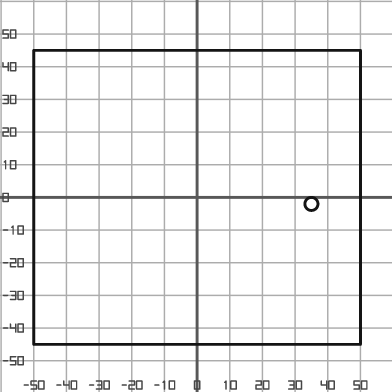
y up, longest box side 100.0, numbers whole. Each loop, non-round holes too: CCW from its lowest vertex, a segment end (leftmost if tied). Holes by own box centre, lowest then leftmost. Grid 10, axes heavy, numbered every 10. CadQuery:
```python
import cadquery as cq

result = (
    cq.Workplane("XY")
    .moveTo(-50.0, -45.0)
    .lineTo(50.0, -45.0)
    .lineTo(50.0, 45.0)
    .lineTo(-50.0, 45.0)
    .close()
    .moveTo(35.0, -2.0)
    .circle(2.0)
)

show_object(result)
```